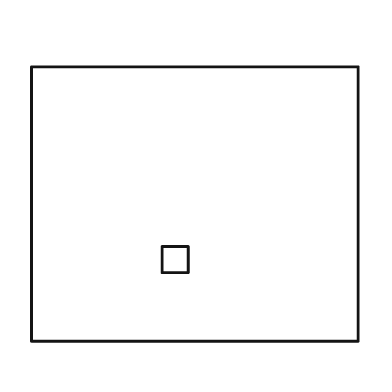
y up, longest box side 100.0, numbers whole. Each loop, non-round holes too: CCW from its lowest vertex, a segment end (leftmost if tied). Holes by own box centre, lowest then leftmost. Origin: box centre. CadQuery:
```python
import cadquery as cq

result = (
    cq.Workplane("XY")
    .moveTo(-50.0, -42.0)
    .lineTo(50.0, -42.0)
    .lineTo(50.0, 42.0)
    .lineTo(-50.0, 42.0)
    .close()
    .moveTo(-10.0, -21.0)
    .lineTo(-2.0, -21.0)
    .lineTo(-2.0, -13.0)
    .lineTo(-10.0, -13.0)
    .close()
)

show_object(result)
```